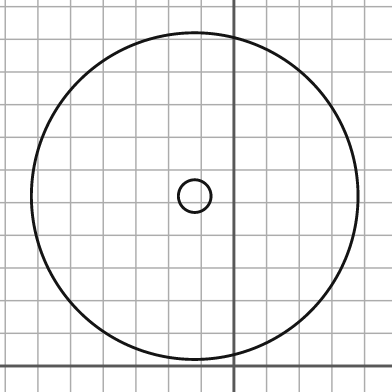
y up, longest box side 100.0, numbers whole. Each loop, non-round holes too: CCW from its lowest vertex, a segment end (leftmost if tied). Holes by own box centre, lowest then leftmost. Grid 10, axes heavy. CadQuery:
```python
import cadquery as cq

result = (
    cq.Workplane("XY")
    .moveTo(-12.0, 52.0)
    .circle(50.0)
    .moveTo(-12.0, 52.0)
    .circle(5.0)
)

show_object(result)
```